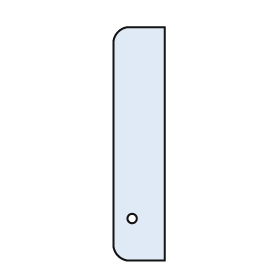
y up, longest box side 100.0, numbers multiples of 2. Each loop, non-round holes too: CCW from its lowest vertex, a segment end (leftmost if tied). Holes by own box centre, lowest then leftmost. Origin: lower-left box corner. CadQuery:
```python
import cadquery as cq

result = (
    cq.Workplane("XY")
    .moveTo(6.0, 0.0)
    .lineTo(22.0, 0.0)
    .lineTo(22.0, 100.0)
    .lineTo(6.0, 100.0)
    .threePointArc((2.0, 98.0), (0.0, 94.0))
    .lineTo(0.0, 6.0)
    .threePointArc((2.0, 2.0), (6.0, 0.0))
    .close()
    .moveTo(8.0, 18.0)
    .circle(2.0)
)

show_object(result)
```